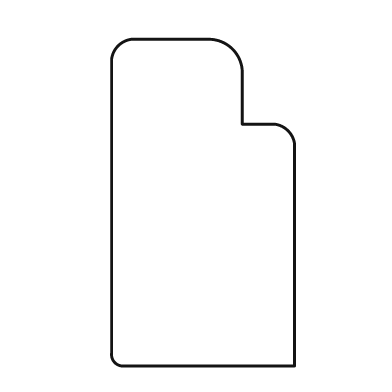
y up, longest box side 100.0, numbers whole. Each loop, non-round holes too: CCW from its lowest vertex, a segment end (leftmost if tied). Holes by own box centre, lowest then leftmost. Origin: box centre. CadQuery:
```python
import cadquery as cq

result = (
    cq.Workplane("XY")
    .moveTo(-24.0, -50.0)
    .lineTo(28.0, -50.0)
    .lineTo(28.0, 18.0)
    .threePointArc((26.0, 22.0), (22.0, 24.0))
    .lineTo(12.0, 24.0)
    .lineTo(12.0, 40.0)
    .threePointArc((9.0, 47.0), (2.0, 50.0))
    .lineTo(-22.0, 50.0)
    .threePointArc((-26.0, 48.0), (-28.0, 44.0))
    .lineTo(-28.0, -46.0)
    .threePointArc((-27.0, -49.0), (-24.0, -50.0))
    .close()
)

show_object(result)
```